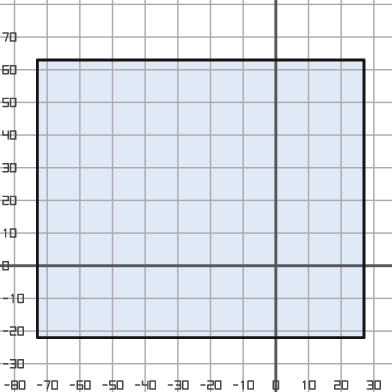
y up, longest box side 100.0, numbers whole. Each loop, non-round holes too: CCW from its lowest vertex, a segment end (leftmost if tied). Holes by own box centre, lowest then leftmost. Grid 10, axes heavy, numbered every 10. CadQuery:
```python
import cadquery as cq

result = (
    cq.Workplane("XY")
    .moveTo(-73.0, -22.0)
    .lineTo(27.0, -22.0)
    .lineTo(27.0, 63.0)
    .lineTo(-73.0, 63.0)
    .close()
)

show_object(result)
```